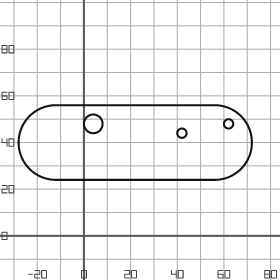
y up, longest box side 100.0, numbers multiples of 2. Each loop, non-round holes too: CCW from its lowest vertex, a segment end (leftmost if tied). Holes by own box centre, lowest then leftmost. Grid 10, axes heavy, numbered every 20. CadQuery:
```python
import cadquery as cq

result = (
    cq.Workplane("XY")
    .moveTo(-12.0, 24.0)
    .lineTo(56.0, 24.0)
    .threePointArc((72.0, 40.0), (56.0, 56.0))
    .lineTo(-12.0, 56.0)
    .threePointArc((-28.0, 40.0), (-12.0, 24.0))
    .close()
    .moveTo(42.0, 44.0)
    .circle(2.0)
    .moveTo(4.0, 48.0)
    .circle(4.0)
    .moveTo(62.0, 48.0)
    .circle(2.0)
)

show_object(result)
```